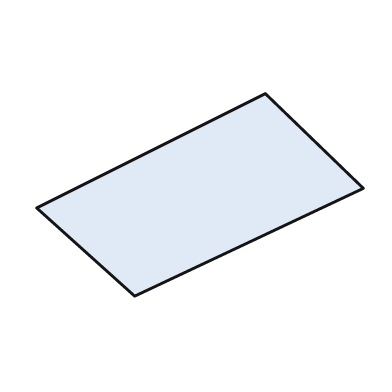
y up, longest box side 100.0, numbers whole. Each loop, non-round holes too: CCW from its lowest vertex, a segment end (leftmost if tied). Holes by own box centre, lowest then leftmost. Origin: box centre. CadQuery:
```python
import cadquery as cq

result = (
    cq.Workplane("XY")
    .moveTo(-20.0, -31.0)
    .lineTo(50.0, 2.0)
    .lineTo(20.0, 31.0)
    .lineTo(-50.0, -4.0)
    .close()
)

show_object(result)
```